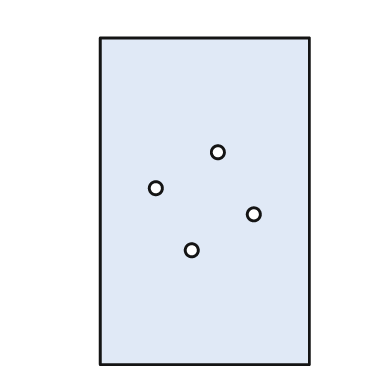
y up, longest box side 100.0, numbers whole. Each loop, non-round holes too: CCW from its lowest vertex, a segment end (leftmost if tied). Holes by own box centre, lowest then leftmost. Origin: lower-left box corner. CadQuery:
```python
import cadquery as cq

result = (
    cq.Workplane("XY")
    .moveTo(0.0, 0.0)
    .lineTo(64.0, 0.0)
    .lineTo(64.0, 100.0)
    .lineTo(0.0, 100.0)
    .close()
    .moveTo(28.0, 35.0)
    .circle(2.0)
    .moveTo(47.0, 46.0)
    .circle(2.0)
    .moveTo(17.0, 54.0)
    .circle(2.0)
    .moveTo(36.0, 65.0)
    .circle(2.0)
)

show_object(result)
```